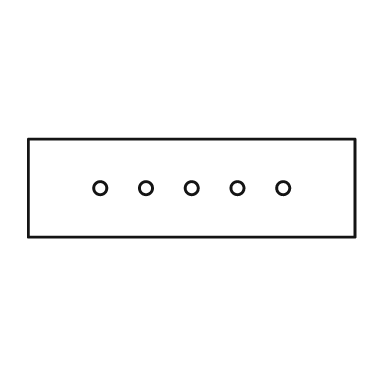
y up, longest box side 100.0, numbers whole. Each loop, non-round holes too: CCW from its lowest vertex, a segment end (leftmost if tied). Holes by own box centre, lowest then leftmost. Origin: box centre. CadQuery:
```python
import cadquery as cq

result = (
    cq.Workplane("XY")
    .moveTo(-50.0, -15.0)
    .lineTo(50.0, -15.0)
    .lineTo(50.0, 15.0)
    .lineTo(-50.0, 15.0)
    .close()
    .moveTo(-28.0, 0.0)
    .circle(2.0)
    .moveTo(-14.0, 0.0)
    .circle(2.0)
    .moveTo(0.0, 0.0)
    .circle(2.0)
    .moveTo(14.0, 0.0)
    .circle(2.0)
    .moveTo(28.0, 0.0)
    .circle(2.0)
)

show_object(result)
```